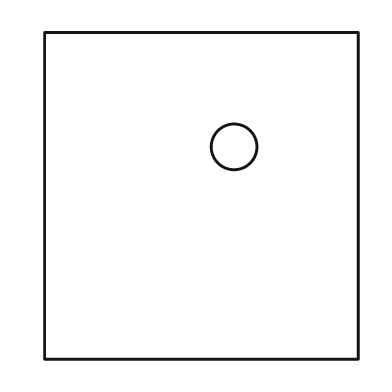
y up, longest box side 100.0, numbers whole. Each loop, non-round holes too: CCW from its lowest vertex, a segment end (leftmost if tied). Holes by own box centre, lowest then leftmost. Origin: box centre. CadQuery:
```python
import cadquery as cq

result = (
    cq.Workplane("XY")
    .moveTo(-48.0, -50.0)
    .lineTo(48.0, -50.0)
    .lineTo(48.0, 50.0)
    .lineTo(-48.0, 50.0)
    .close()
    .moveTo(10.0, 15.0)
    .circle(7.0)
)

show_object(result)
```